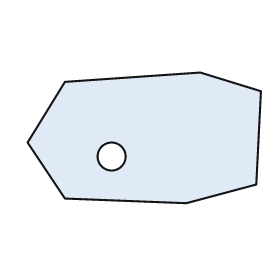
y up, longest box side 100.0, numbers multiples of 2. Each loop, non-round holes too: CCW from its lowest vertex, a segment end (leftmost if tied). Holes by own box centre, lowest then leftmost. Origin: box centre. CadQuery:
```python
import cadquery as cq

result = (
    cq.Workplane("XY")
    .moveTo(18.0, -28.0)
    .lineTo(48.0, -20.0)
    .lineTo(50.0, 20.0)
    .lineTo(24.0, 28.0)
    .lineTo(-34.0, 24.0)
    .lineTo(-50.0, -2.0)
    .lineTo(-34.0, -26.0)
    .close()
    .moveTo(-14.0, -8.0)
    .circle(6.0)
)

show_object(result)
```